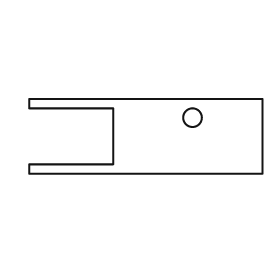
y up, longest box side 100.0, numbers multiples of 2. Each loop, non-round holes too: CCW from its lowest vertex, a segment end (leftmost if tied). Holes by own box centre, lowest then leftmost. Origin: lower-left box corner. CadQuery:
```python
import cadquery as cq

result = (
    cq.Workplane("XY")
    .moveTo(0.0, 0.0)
    .lineTo(100.0, 0.0)
    .lineTo(100.0, 32.0)
    .lineTo(0.0, 32.0)
    .lineTo(0.0, 28.0)
    .lineTo(36.0, 28.0)
    .lineTo(36.0, 4.0)
    .lineTo(0.0, 4.0)
    .close()
    .moveTo(70.0, 24.0)
    .circle(4.0)
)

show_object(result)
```